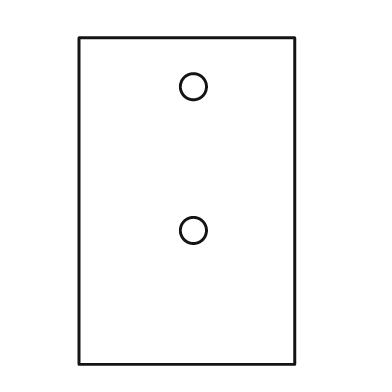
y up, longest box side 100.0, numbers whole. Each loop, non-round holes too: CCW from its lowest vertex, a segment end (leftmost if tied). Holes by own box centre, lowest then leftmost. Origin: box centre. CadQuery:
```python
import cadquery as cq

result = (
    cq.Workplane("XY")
    .moveTo(-33.0, -50.0)
    .lineTo(33.0, -50.0)
    .lineTo(33.0, 50.0)
    .lineTo(-33.0, 50.0)
    .close()
    .moveTo(2.0, -9.0)
    .circle(4.0)
    .moveTo(2.0, 35.0)
    .circle(4.0)
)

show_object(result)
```